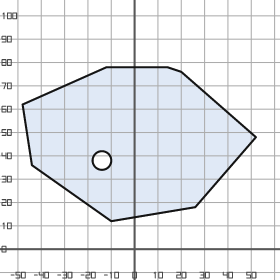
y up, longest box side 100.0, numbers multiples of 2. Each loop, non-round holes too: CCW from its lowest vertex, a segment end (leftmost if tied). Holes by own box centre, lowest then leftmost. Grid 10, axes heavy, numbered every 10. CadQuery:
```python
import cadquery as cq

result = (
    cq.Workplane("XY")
    .moveTo(-10.0, 12.0)
    .lineTo(26.0, 18.0)
    .lineTo(52.0, 48.0)
    .lineTo(20.0, 76.0)
    .lineTo(14.0, 78.0)
    .lineTo(-12.0, 78.0)
    .lineTo(-48.0, 62.0)
    .lineTo(-44.0, 36.0)
    .close()
    .moveTo(-14.0, 38.0)
    .circle(4.0)
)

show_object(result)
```